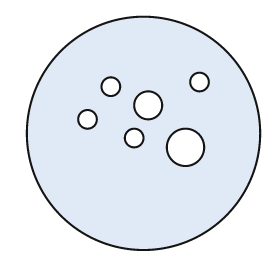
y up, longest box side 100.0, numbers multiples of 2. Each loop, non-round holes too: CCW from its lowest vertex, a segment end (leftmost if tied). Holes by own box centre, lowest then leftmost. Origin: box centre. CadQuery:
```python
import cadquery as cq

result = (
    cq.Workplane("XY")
    .moveTo(0.0, 0.0)
    .circle(50.0)
    .moveTo(18.0, -6.0)
    .circle(8.0)
    .moveTo(-4.0, -2.0)
    .circle(4.0)
    .moveTo(-24.0, 6.0)
    .circle(4.0)
    .moveTo(2.0, 12.0)
    .circle(6.0)
    .moveTo(-14.0, 20.0)
    .circle(4.0)
    .moveTo(24.0, 22.0)
    .circle(4.0)
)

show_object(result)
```